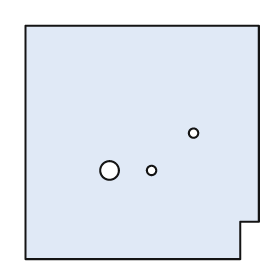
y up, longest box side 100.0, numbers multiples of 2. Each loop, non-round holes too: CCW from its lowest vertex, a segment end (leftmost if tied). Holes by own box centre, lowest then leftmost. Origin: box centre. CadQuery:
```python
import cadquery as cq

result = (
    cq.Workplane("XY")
    .moveTo(-50.0, -50.0)
    .lineTo(42.0, -50.0)
    .lineTo(42.0, -34.0)
    .lineTo(50.0, -34.0)
    .lineTo(50.0, 50.0)
    .lineTo(-50.0, 50.0)
    .close()
    .moveTo(-14.0, -12.0)
    .circle(4.0)
    .moveTo(4.0, -12.0)
    .circle(2.0)
    .moveTo(22.0, 4.0)
    .circle(2.0)
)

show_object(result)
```